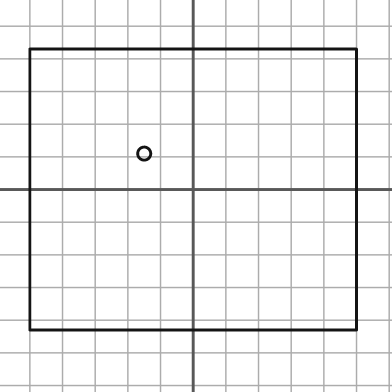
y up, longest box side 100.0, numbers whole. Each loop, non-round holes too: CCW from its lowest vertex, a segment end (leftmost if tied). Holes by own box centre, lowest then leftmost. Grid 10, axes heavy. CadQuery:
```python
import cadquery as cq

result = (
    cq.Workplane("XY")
    .moveTo(-50.0, -43.0)
    .lineTo(50.0, -43.0)
    .lineTo(50.0, 43.0)
    .lineTo(-50.0, 43.0)
    .close()
    .moveTo(-15.0, 11.0)
    .circle(2.0)
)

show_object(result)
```